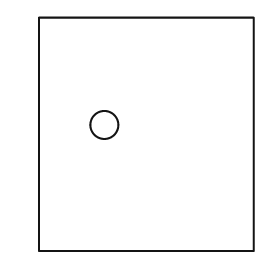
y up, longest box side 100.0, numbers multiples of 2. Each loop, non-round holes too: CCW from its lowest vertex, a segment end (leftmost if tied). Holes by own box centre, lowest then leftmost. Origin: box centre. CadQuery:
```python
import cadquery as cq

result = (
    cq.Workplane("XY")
    .moveTo(-46.0, -50.0)
    .lineTo(46.0, -50.0)
    .lineTo(46.0, 50.0)
    .lineTo(-46.0, 50.0)
    .close()
    .moveTo(-18.0, 4.0)
    .circle(6.0)
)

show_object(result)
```